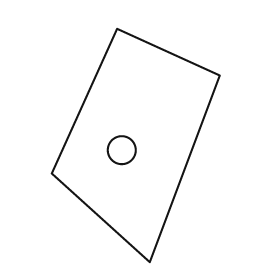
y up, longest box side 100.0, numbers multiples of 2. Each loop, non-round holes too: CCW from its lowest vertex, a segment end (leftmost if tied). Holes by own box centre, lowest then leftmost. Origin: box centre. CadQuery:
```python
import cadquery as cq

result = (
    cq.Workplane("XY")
    .moveTo(6.0, -50.0)
    .lineTo(36.0, 30.0)
    .lineTo(-8.0, 50.0)
    .lineTo(-36.0, -12.0)
    .close()
    .moveTo(-6.0, -2.0)
    .circle(6.0)
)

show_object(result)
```